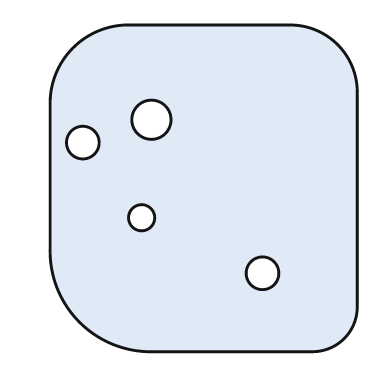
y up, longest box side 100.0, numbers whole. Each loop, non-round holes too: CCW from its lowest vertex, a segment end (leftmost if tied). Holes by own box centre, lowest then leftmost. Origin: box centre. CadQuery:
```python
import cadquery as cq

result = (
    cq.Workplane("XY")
    .moveTo(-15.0, -50.0)
    .lineTo(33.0, -50.0)
    .threePointArc((43.0, -46.0), (47.0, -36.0))
    .lineTo(47.0, 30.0)
    .threePointArc((41.0, 44.0), (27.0, 50.0))
    .lineTo(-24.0, 50.0)
    .threePointArc((-40.0, 43.0), (-47.0, 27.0))
    .lineTo(-47.0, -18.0)
    .threePointArc((-38.0, -41.0), (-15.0, -50.0))
    .close()
    .moveTo(18.0, -26.0)
    .circle(5.0)
    .moveTo(-19.0, -9.0)
    .circle(4.0)
    .moveTo(-37.0, 14.0)
    .circle(5.0)
    .moveTo(-16.0, 21.0)
    .circle(6.0)
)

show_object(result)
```